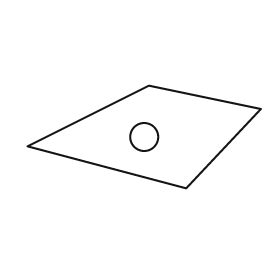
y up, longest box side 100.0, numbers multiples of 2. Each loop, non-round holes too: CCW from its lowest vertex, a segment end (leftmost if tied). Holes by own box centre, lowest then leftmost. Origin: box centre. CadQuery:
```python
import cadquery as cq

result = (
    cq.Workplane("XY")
    .moveTo(18.0, -22.0)
    .lineTo(50.0, 12.0)
    .lineTo(2.0, 22.0)
    .lineTo(-50.0, -4.0)
    .close()
    .moveTo(0.0, 0.0)
    .circle(6.0)
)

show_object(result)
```